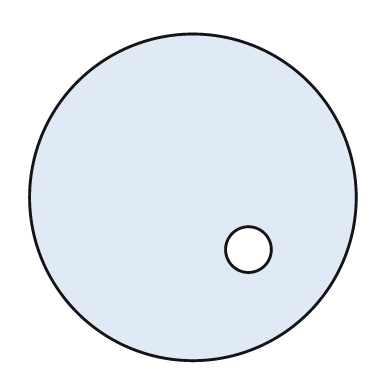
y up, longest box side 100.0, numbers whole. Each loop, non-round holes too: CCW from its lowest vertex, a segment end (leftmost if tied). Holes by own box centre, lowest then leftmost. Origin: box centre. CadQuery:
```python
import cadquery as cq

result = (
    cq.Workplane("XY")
    .moveTo(0.0, 0.0)
    .circle(50.0)
    .moveTo(17.0, -16.0)
    .circle(7.0)
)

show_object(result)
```